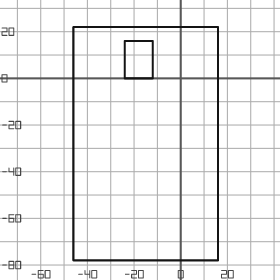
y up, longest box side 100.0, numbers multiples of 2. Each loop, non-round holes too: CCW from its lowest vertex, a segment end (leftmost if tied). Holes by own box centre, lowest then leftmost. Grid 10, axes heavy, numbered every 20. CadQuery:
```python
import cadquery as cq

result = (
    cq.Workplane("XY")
    .moveTo(-46.0, -78.0)
    .lineTo(16.0, -78.0)
    .lineTo(16.0, 22.0)
    .lineTo(-46.0, 22.0)
    .close()
    .moveTo(-24.0, 0.0)
    .lineTo(-12.0, 0.0)
    .lineTo(-12.0, 16.0)
    .lineTo(-24.0, 16.0)
    .close()
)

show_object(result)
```